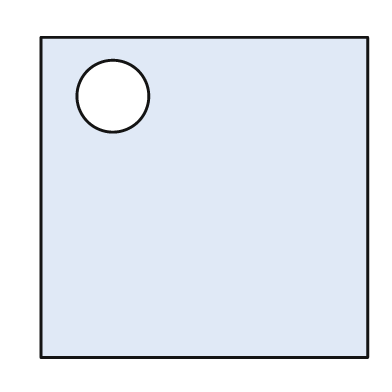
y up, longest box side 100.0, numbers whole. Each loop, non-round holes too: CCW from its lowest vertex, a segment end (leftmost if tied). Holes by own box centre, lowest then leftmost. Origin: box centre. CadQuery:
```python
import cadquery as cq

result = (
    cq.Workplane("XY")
    .moveTo(-50.0, -49.0)
    .lineTo(50.0, -49.0)
    .lineTo(50.0, 49.0)
    .lineTo(-50.0, 49.0)
    .close()
    .moveTo(-28.0, 31.0)
    .circle(11.0)
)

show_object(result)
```